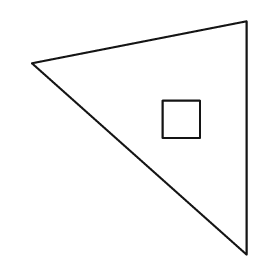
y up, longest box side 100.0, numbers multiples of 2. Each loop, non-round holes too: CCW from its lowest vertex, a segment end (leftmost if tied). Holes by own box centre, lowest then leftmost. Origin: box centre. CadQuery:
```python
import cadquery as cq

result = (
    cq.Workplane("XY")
    .moveTo(46.0, -50.0)
    .lineTo(46.0, 50.0)
    .lineTo(-46.0, 32.0)
    .close()
    .moveTo(10.0, 0.0)
    .lineTo(26.0, 0.0)
    .lineTo(26.0, 16.0)
    .lineTo(10.0, 16.0)
    .close()
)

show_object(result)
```